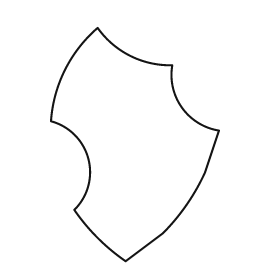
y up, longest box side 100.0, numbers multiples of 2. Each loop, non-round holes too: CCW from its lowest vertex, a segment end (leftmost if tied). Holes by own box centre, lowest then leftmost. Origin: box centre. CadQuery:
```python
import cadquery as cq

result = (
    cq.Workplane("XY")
    .moveTo(-4.0, -50.0)
    .lineTo(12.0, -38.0)
    .threePointArc((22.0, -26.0), (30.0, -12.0))
    .lineTo(36.0, 6.0)
    .threePointArc((20.0, 16.0), (16.0, 34.0))
    .threePointArc((-2.0, 38.0), (-16.0, 50.0))
    .threePointArc((-30.0, 32.0), (-36.0, 10.0))
    .threePointArc((-20.0, -6.0), (-26.0, -28.0))
    .threePointArc((-16.0, -40.0), (-4.0, -50.0))
    .close()
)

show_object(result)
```